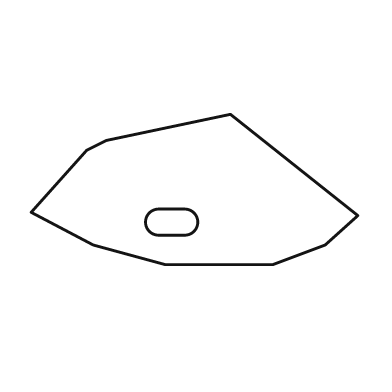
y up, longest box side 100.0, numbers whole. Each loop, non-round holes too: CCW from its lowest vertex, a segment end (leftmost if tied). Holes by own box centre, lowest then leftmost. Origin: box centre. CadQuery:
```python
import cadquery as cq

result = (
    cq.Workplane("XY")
    .moveTo(-9.0, -23.0)
    .lineTo(24.0, -23.0)
    .lineTo(40.0, -17.0)
    .lineTo(50.0, -8.0)
    .lineTo(11.0, 23.0)
    .lineTo(-27.0, 15.0)
    .lineTo(-33.0, 12.0)
    .lineTo(-50.0, -7.0)
    .lineTo(-31.0, -17.0)
    .close()
    .moveTo(-11.0, -14.0)
    .lineTo(-3.0, -14.0)
    .threePointArc((1.0, -10.0), (-3.0, -6.0))
    .lineTo(-11.0, -6.0)
    .threePointArc((-15.0, -10.0), (-11.0, -14.0))
    .close()
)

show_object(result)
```